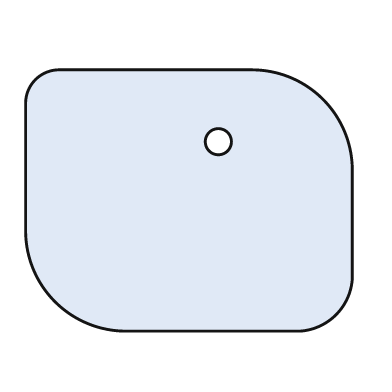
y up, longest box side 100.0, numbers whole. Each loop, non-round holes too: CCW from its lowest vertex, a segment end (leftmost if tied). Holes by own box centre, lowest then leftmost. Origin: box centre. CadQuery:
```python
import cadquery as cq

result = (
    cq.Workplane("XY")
    .moveTo(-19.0, -40.0)
    .lineTo(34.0, -40.0)
    .threePointArc((45.0, -35.0), (50.0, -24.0))
    .lineTo(50.0, 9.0)
    .threePointArc((41.0, 31.0), (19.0, 40.0))
    .lineTo(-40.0, 40.0)
    .threePointArc((-47.0, 37.0), (-50.0, 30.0))
    .lineTo(-50.0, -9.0)
    .threePointArc((-41.0, -31.0), (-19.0, -40.0))
    .close()
    .moveTo(9.0, 18.0)
    .circle(4.0)
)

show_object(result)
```